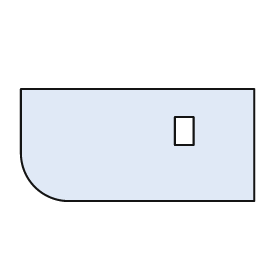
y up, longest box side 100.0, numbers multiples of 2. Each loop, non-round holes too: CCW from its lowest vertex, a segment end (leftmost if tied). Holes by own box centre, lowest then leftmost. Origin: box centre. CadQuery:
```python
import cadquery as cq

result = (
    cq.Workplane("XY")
    .moveTo(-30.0, -24.0)
    .lineTo(50.0, -24.0)
    .lineTo(50.0, 24.0)
    .lineTo(-50.0, 24.0)
    .lineTo(-50.0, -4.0)
    .threePointArc((-44.0, -18.0), (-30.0, -24.0))
    .close()
    .moveTo(16.0, 0.0)
    .lineTo(24.0, 0.0)
    .lineTo(24.0, 12.0)
    .lineTo(16.0, 12.0)
    .close()
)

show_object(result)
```